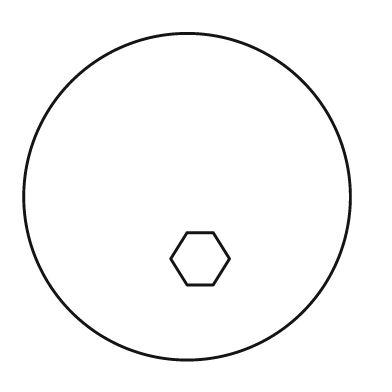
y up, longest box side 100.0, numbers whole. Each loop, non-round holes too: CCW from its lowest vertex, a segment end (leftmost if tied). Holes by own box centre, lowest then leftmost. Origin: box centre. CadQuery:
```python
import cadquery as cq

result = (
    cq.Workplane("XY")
    .moveTo(0.0, 0.0)
    .circle(50.0)
    .moveTo(0.0, -27.0)
    .lineTo(8.0, -27.0)
    .lineTo(13.0, -19.0)
    .lineTo(8.0, -11.0)
    .lineTo(0.0, -11.0)
    .lineTo(-5.0, -19.0)
    .close()
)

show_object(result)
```